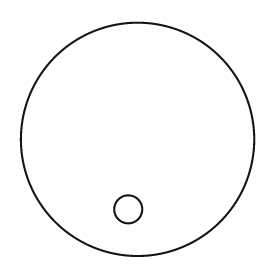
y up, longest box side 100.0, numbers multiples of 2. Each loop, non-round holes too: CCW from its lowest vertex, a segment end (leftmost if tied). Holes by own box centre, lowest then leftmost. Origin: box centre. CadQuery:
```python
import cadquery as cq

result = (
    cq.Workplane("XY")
    .moveTo(0.0, 0.0)
    .circle(50.0)
    .moveTo(-4.0, -30.0)
    .circle(6.0)
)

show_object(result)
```